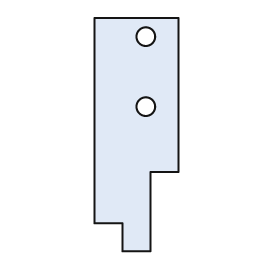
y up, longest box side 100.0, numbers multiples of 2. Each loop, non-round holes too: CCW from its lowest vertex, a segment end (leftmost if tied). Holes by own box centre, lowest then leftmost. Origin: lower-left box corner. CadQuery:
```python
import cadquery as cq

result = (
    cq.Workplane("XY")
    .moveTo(12.0, 0.0)
    .lineTo(24.0, 0.0)
    .lineTo(24.0, 34.0)
    .lineTo(36.0, 34.0)
    .lineTo(36.0, 100.0)
    .lineTo(0.0, 100.0)
    .lineTo(0.0, 12.0)
    .lineTo(12.0, 12.0)
    .close()
    .moveTo(22.0, 62.0)
    .circle(4.0)
    .moveTo(22.0, 92.0)
    .circle(4.0)
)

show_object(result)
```